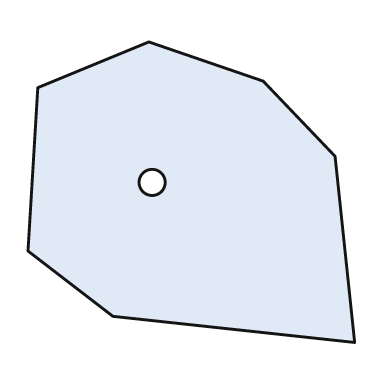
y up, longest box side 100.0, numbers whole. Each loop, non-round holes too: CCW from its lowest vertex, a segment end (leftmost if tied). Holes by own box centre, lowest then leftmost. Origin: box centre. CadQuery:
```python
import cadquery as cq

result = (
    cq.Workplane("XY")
    .moveTo(50.0, -46.0)
    .lineTo(44.0, 11.0)
    .lineTo(22.0, 34.0)
    .lineTo(-13.0, 46.0)
    .lineTo(-47.0, 32.0)
    .lineTo(-50.0, -18.0)
    .lineTo(-24.0, -38.0)
    .close()
    .moveTo(-12.0, 3.0)
    .circle(4.0)
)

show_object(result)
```